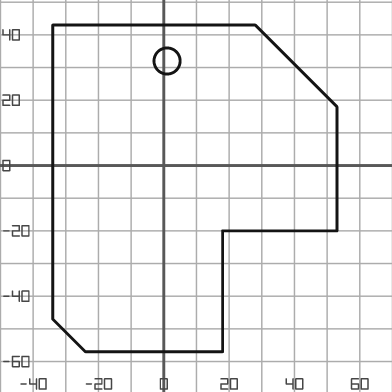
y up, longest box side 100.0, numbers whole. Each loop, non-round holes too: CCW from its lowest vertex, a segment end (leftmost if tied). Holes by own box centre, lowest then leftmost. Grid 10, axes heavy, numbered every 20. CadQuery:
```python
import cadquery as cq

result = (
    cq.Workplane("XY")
    .moveTo(-24.0, -57.0)
    .lineTo(18.0, -57.0)
    .lineTo(18.0, -20.0)
    .lineTo(53.0, -20.0)
    .lineTo(53.0, 18.0)
    .lineTo(28.0, 43.0)
    .lineTo(-34.0, 43.0)
    .lineTo(-34.0, -47.0)
    .close()
    .moveTo(1.0, 32.0)
    .circle(4.0)
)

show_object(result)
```